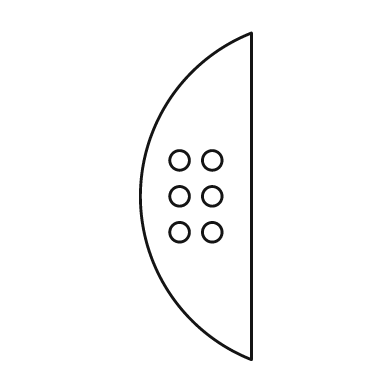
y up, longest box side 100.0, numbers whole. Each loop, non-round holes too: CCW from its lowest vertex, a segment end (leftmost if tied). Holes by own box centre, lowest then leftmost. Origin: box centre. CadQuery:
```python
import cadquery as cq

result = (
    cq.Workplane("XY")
    .moveTo(17.0, -50.0)
    .lineTo(17.0, 50.0)
    .threePointArc((-17.0, 0.0), (17.0, -50.0))
    .close()
    .moveTo(-5.0, -11.0)
    .circle(3.0)
    .moveTo(5.0, -11.0)
    .circle(3.0)
    .moveTo(-5.0, 0.0)
    .circle(3.0)
    .moveTo(5.0, 0.0)
    .circle(3.0)
    .moveTo(-5.0, 11.0)
    .circle(3.0)
    .moveTo(5.0, 11.0)
    .circle(3.0)
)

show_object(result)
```